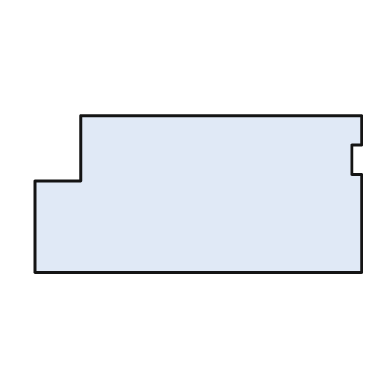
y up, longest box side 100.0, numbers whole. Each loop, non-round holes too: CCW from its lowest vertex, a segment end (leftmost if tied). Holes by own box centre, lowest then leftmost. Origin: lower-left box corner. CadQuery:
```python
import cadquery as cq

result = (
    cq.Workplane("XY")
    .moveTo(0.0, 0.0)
    .lineTo(100.0, 0.0)
    .lineTo(100.0, 30.0)
    .lineTo(97.0, 30.0)
    .lineTo(97.0, 39.0)
    .lineTo(100.0, 39.0)
    .lineTo(100.0, 48.0)
    .lineTo(14.0, 48.0)
    .lineTo(14.0, 28.0)
    .lineTo(0.0, 28.0)
    .close()
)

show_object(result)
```